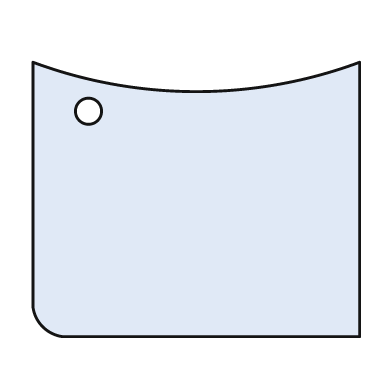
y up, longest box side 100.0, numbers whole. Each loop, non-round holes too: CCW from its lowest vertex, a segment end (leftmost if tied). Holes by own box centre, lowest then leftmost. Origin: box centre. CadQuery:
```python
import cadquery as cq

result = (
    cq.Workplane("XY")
    .moveTo(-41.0, -42.0)
    .lineTo(50.0, -42.0)
    .lineTo(50.0, 42.0)
    .threePointArc((0.0, 33.0), (-50.0, 42.0))
    .lineTo(-50.0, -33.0)
    .threePointArc((-47.0, -39.0), (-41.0, -42.0))
    .close()
    .moveTo(-33.0, 27.0)
    .circle(4.0)
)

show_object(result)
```